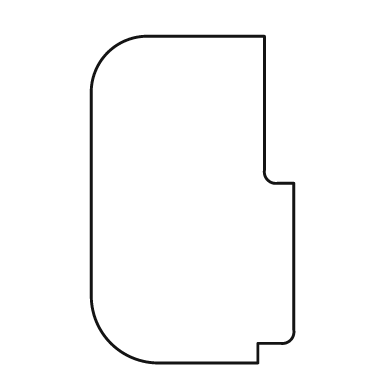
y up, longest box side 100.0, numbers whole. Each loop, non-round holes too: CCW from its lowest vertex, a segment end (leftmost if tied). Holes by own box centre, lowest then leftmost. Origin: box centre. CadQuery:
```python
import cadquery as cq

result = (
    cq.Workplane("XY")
    .moveTo(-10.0, -50.0)
    .lineTo(20.0, -50.0)
    .lineTo(20.0, -44.0)
    .lineTo(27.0, -44.0)
    .threePointArc((30.0, -43.0), (31.0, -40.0))
    .lineTo(31.0, 5.0)
    .lineTo(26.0, 5.0)
    .threePointArc((23.0, 6.0), (22.0, 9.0))
    .lineTo(22.0, 50.0)
    .lineTo(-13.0, 50.0)
    .threePointArc((-26.0, 45.0), (-31.0, 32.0))
    .lineTo(-31.0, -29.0)
    .threePointArc((-25.0, -44.0), (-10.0, -50.0))
    .close()
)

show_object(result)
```